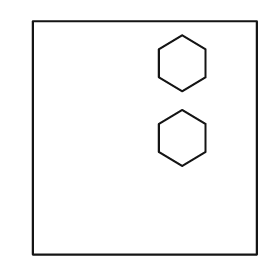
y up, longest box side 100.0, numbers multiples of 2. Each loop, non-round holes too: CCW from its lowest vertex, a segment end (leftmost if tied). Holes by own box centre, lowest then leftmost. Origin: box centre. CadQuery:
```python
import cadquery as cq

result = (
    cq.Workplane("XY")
    .moveTo(-48.0, -50.0)
    .lineTo(48.0, -50.0)
    .lineTo(48.0, 50.0)
    .lineTo(-48.0, 50.0)
    .close()
    .moveTo(16.0, -12.0)
    .lineTo(26.0, -6.0)
    .lineTo(26.0, 6.0)
    .lineTo(16.0, 12.0)
    .lineTo(6.0, 6.0)
    .lineTo(6.0, -6.0)
    .close()
    .moveTo(16.0, 20.0)
    .lineTo(26.0, 26.0)
    .lineTo(26.0, 38.0)
    .lineTo(16.0, 44.0)
    .lineTo(6.0, 38.0)
    .lineTo(6.0, 26.0)
    .close()
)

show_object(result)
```